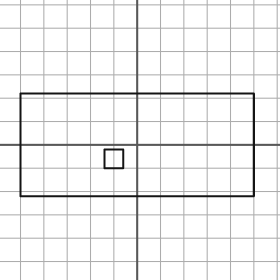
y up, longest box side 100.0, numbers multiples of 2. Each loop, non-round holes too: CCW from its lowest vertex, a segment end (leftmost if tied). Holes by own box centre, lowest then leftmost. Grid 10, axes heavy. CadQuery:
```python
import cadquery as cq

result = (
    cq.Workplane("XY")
    .moveTo(-50.0, -22.0)
    .lineTo(50.0, -22.0)
    .lineTo(50.0, 22.0)
    .lineTo(-50.0, 22.0)
    .close()
    .moveTo(-14.0, -10.0)
    .lineTo(-6.0, -10.0)
    .lineTo(-6.0, -2.0)
    .lineTo(-14.0, -2.0)
    .close()
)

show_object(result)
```